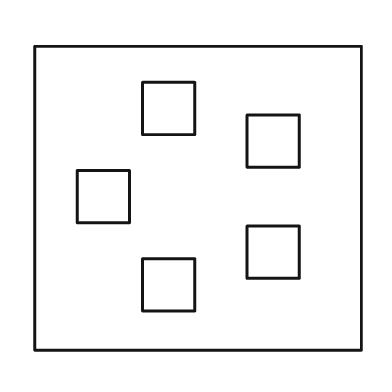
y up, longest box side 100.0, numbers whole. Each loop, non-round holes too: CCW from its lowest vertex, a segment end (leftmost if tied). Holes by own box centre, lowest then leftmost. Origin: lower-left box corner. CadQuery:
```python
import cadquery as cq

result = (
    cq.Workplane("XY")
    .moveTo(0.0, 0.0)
    .lineTo(100.0, 0.0)
    .lineTo(100.0, 93.0)
    .lineTo(0.0, 93.0)
    .close()
    .moveTo(33.0, 12.0)
    .lineTo(49.0, 12.0)
    .lineTo(49.0, 28.0)
    .lineTo(33.0, 28.0)
    .close()
    .moveTo(65.0, 22.0)
    .lineTo(81.0, 22.0)
    .lineTo(81.0, 38.0)
    .lineTo(65.0, 38.0)
    .close()
    .moveTo(13.0, 39.0)
    .lineTo(29.0, 39.0)
    .lineTo(29.0, 55.0)
    .lineTo(13.0, 55.0)
    .close()
    .moveTo(65.0, 56.0)
    .lineTo(81.0, 56.0)
    .lineTo(81.0, 72.0)
    .lineTo(65.0, 72.0)
    .close()
    .moveTo(33.0, 66.0)
    .lineTo(49.0, 66.0)
    .lineTo(49.0, 82.0)
    .lineTo(33.0, 82.0)
    .close()
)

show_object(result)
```